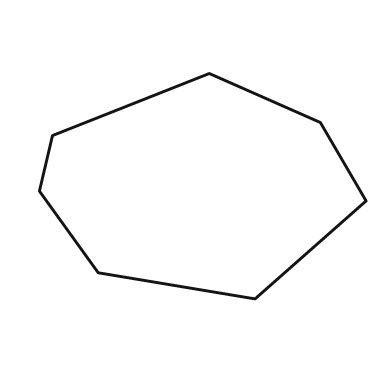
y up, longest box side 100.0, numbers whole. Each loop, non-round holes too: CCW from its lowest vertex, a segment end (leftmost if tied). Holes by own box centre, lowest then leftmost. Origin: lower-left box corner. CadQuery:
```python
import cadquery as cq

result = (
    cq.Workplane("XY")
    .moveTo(66.0, 0.0)
    .lineTo(100.0, 30.0)
    .lineTo(86.0, 54.0)
    .lineTo(52.0, 69.0)
    .lineTo(4.0, 50.0)
    .lineTo(0.0, 33.0)
    .lineTo(18.0, 8.0)
    .close()
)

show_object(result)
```